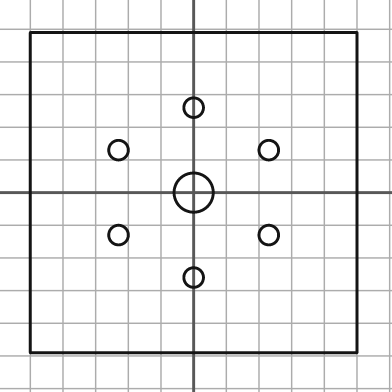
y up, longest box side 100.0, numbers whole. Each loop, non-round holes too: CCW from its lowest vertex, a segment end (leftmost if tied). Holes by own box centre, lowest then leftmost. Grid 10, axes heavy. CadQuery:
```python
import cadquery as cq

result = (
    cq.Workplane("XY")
    .moveTo(-50.0, -49.0)
    .lineTo(50.0, -49.0)
    .lineTo(50.0, 49.0)
    .lineTo(-50.0, 49.0)
    .close()
    .moveTo(0.0, -26.0)
    .circle(3.0)
    .moveTo(-23.0, -13.0)
    .circle(3.0)
    .moveTo(23.0, -13.0)
    .circle(3.0)
    .moveTo(0.0, 0.0)
    .circle(6.0)
    .moveTo(-23.0, 13.0)
    .circle(3.0)
    .moveTo(23.0, 13.0)
    .circle(3.0)
    .moveTo(0.0, 26.0)
    .circle(3.0)
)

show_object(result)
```